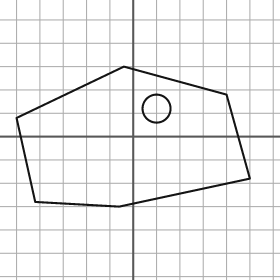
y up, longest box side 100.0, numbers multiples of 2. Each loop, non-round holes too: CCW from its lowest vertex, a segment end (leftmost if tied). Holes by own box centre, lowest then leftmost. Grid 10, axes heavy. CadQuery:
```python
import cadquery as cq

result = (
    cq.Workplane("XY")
    .moveTo(-6.0, -30.0)
    .lineTo(50.0, -18.0)
    .lineTo(40.0, 18.0)
    .lineTo(-4.0, 30.0)
    .lineTo(-50.0, 8.0)
    .lineTo(-42.0, -28.0)
    .close()
    .moveTo(10.0, 12.0)
    .circle(6.0)
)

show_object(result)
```